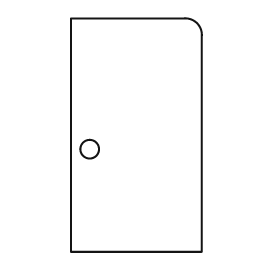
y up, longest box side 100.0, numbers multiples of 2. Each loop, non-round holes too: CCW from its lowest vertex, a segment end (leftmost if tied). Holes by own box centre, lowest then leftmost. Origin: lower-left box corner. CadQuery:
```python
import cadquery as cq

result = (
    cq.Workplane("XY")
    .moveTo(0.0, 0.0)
    .lineTo(56.0, 0.0)
    .lineTo(56.0, 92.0)
    .threePointArc((54.0, 98.0), (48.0, 100.0))
    .lineTo(0.0, 100.0)
    .close()
    .moveTo(8.0, 44.0)
    .circle(4.0)
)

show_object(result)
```